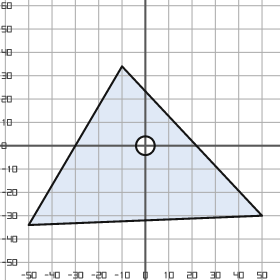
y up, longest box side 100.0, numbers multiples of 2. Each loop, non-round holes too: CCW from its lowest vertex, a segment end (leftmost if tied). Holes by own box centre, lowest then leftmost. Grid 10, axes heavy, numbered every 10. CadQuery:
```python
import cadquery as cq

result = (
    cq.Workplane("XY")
    .moveTo(-50.0, -34.0)
    .lineTo(50.0, -30.0)
    .lineTo(-10.0, 34.0)
    .close()
    .moveTo(0.0, 0.0)
    .circle(4.0)
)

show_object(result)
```